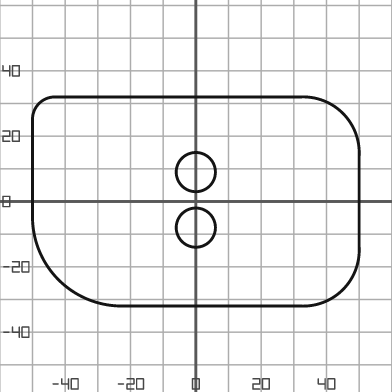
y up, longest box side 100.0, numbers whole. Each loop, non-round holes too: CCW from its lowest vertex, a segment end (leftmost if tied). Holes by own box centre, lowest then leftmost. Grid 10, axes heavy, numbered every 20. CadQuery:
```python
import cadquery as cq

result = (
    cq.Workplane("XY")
    .moveTo(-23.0, -32.0)
    .lineTo(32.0, -32.0)
    .threePointArc((45.0, -27.0), (50.0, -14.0))
    .lineTo(50.0, 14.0)
    .threePointArc((45.0, 27.0), (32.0, 32.0))
    .lineTo(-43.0, 32.0)
    .threePointArc((-48.0, 30.0), (-50.0, 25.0))
    .lineTo(-50.0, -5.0)
    .threePointArc((-42.0, -24.0), (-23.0, -32.0))
    .close()
    .moveTo(0.0, -8.0)
    .circle(6.0)
    .moveTo(0.0, 9.0)
    .circle(6.0)
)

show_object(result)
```